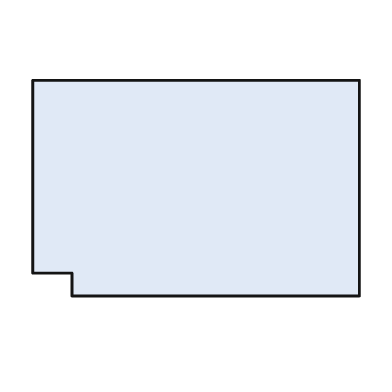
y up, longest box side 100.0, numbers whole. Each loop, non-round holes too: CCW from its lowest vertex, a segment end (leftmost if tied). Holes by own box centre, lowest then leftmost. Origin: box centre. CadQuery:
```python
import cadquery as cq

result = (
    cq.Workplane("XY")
    .moveTo(-38.0, -33.0)
    .lineTo(50.0, -33.0)
    .lineTo(50.0, 33.0)
    .lineTo(-50.0, 33.0)
    .lineTo(-50.0, -26.0)
    .lineTo(-38.0, -26.0)
    .close()
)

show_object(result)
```